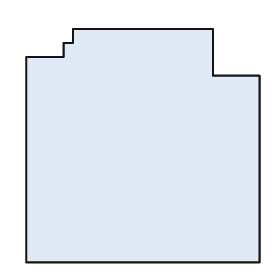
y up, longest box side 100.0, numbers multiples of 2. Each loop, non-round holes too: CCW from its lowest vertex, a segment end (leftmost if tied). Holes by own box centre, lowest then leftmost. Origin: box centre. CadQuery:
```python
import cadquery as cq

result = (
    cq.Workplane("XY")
    .moveTo(-50.0, -50.0)
    .lineTo(50.0, -50.0)
    .lineTo(50.0, 30.0)
    .lineTo(30.0, 30.0)
    .lineTo(30.0, 50.0)
    .lineTo(-30.0, 50.0)
    .lineTo(-30.0, 44.0)
    .lineTo(-34.0, 44.0)
    .lineTo(-34.0, 38.0)
    .lineTo(-50.0, 38.0)
    .close()
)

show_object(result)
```